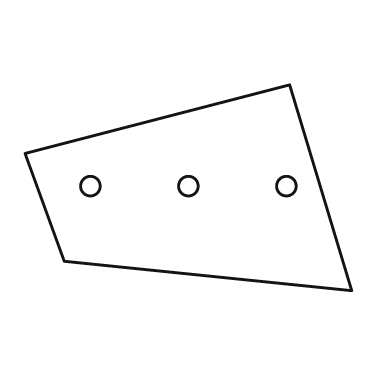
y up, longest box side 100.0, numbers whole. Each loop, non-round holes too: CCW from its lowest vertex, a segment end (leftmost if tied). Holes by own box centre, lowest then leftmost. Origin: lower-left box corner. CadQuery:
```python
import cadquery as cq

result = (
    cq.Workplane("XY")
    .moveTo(100.0, 0.0)
    .lineTo(81.0, 63.0)
    .lineTo(0.0, 42.0)
    .lineTo(12.0, 9.0)
    .close()
    .moveTo(20.0, 32.0)
    .circle(3.0)
    .moveTo(50.0, 32.0)
    .circle(3.0)
    .moveTo(80.0, 32.0)
    .circle(3.0)
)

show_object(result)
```